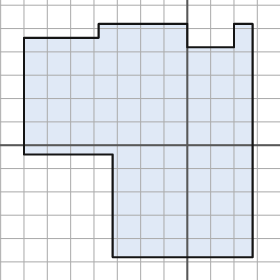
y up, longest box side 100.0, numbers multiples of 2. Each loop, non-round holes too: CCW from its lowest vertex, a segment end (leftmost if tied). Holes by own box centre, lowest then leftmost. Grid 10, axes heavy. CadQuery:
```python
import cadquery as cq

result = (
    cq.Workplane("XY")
    .moveTo(-32.0, -48.0)
    .lineTo(28.0, -48.0)
    .lineTo(28.0, 52.0)
    .lineTo(20.0, 52.0)
    .lineTo(20.0, 42.0)
    .lineTo(0.0, 42.0)
    .lineTo(0.0, 52.0)
    .lineTo(-38.0, 52.0)
    .lineTo(-38.0, 46.0)
    .lineTo(-70.0, 46.0)
    .lineTo(-70.0, -4.0)
    .lineTo(-32.0, -4.0)
    .close()
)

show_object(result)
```